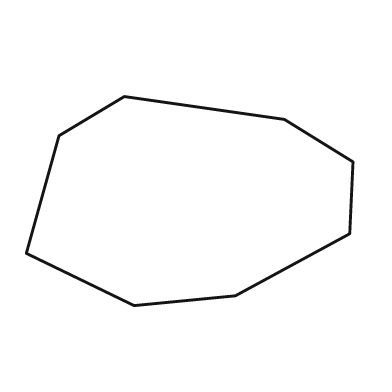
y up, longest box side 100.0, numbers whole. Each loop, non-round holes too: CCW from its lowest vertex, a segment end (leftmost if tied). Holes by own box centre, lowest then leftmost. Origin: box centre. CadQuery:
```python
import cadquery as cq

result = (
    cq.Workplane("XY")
    .moveTo(-17.0, -32.0)
    .lineTo(14.0, -29.0)
    .lineTo(49.0, -10.0)
    .lineTo(50.0, 12.0)
    .lineTo(29.0, 25.0)
    .lineTo(-20.0, 32.0)
    .lineTo(-40.0, 20.0)
    .lineTo(-50.0, -16.0)
    .close()
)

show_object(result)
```